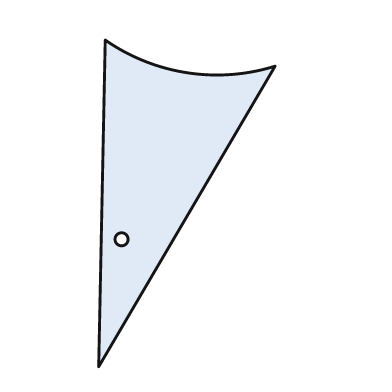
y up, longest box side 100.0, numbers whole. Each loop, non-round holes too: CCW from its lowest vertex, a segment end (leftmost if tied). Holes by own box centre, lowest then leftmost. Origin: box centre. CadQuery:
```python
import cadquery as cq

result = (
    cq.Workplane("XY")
    .moveTo(-27.0, -50.0)
    .lineTo(27.0, 42.0)
    .threePointArc((0.0, 40.0), (-25.0, 50.0))
    .close()
    .moveTo(-20.0, -11.0)
    .circle(2.0)
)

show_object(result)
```